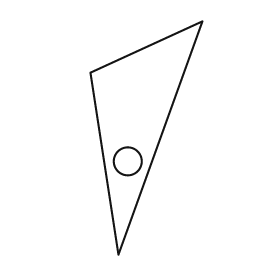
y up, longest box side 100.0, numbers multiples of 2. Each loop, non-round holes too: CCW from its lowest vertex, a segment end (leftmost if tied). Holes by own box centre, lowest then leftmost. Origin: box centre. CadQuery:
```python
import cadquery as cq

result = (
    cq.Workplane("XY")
    .moveTo(-12.0, -50.0)
    .lineTo(24.0, 50.0)
    .lineTo(-24.0, 28.0)
    .close()
    .moveTo(-8.0, -10.0)
    .circle(6.0)
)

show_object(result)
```